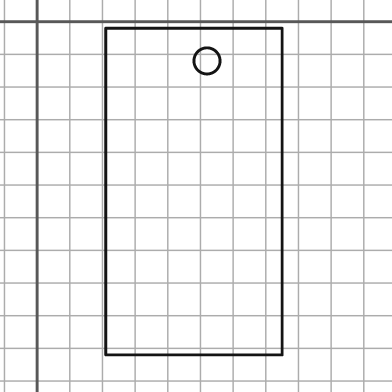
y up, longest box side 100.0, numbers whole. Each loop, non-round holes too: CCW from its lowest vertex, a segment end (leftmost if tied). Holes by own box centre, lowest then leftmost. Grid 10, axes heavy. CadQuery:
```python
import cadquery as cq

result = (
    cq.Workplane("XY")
    .moveTo(21.0, -102.0)
    .lineTo(75.0, -102.0)
    .lineTo(75.0, -2.0)
    .lineTo(21.0, -2.0)
    .close()
    .moveTo(52.0, -12.0)
    .circle(4.0)
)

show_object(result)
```